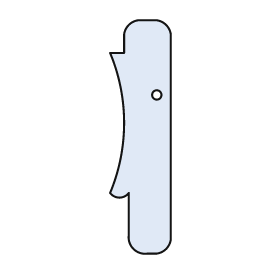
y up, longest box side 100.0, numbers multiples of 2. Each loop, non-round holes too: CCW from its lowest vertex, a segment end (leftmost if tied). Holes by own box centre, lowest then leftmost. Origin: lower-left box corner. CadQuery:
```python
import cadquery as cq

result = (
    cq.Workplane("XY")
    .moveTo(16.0, 0.0)
    .lineTo(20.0, 0.0)
    .threePointArc((24.0, 2.0), (26.0, 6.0))
    .lineTo(26.0, 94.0)
    .threePointArc((24.0, 98.0), (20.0, 100.0))
    .lineTo(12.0, 100.0)
    .threePointArc((8.0, 98.0), (6.0, 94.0))
    .lineTo(6.0, 86.0)
    .lineTo(0.0, 86.0)
    .threePointArc((6.0, 56.0), (0.0, 26.0))
    .threePointArc((4.0, 24.0), (8.0, 26.0))
    .lineTo(8.0, 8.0)
    .threePointArc((10.0, 2.0), (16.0, 0.0))
    .close()
    .moveTo(20.0, 68.0)
    .circle(2.0)
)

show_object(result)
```